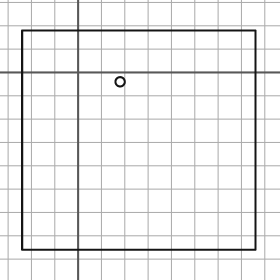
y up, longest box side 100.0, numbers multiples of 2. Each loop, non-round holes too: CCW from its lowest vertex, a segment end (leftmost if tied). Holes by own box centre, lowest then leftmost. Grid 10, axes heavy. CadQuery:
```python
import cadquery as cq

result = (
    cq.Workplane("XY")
    .moveTo(-24.0, -76.0)
    .lineTo(76.0, -76.0)
    .lineTo(76.0, 18.0)
    .lineTo(-24.0, 18.0)
    .close()
    .moveTo(18.0, -4.0)
    .circle(2.0)
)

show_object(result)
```